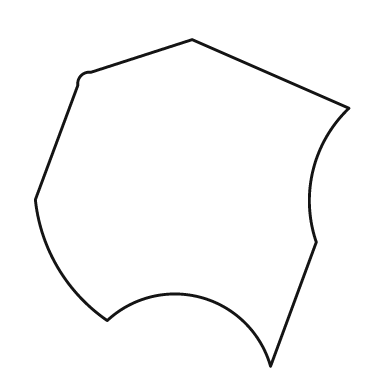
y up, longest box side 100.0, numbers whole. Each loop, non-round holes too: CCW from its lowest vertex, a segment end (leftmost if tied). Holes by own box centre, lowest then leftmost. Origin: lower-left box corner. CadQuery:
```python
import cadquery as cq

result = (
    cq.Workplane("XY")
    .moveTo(72.0, 0.0)
    .lineTo(86.0, 38.0)
    .threePointArc((85.0, 60.0), (96.0, 79.0))
    .lineTo(48.0, 100.0)
    .lineTo(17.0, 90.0)
    .threePointArc((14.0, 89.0), (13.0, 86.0))
    .lineTo(0.0, 51.0)
    .threePointArc((7.0, 30.0), (22.0, 14.0))
    .threePointArc((51.0, 21.0), (72.0, 0.0))
    .close()
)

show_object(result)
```